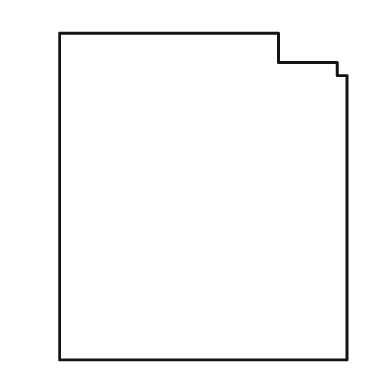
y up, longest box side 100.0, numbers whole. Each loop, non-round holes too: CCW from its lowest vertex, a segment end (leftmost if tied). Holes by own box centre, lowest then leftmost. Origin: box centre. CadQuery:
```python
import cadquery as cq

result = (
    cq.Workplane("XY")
    .moveTo(-44.0, -50.0)
    .lineTo(44.0, -50.0)
    .lineTo(44.0, 37.0)
    .lineTo(41.0, 37.0)
    .lineTo(41.0, 41.0)
    .lineTo(23.0, 41.0)
    .lineTo(23.0, 50.0)
    .lineTo(-44.0, 50.0)
    .close()
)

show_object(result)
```